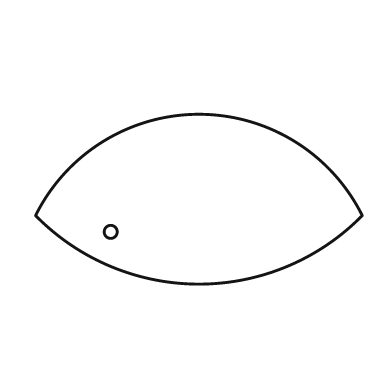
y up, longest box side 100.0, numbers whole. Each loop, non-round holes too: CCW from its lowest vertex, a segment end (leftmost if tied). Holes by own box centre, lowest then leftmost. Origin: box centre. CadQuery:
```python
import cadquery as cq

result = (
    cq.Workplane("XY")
    .moveTo(-50.0, -5.0)
    .threePointArc((0.0, -26.0), (50.0, -5.0))
    .threePointArc((0.0, 26.0), (-50.0, -5.0))
    .close()
    .moveTo(-27.0, -10.0)
    .circle(2.0)
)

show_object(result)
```